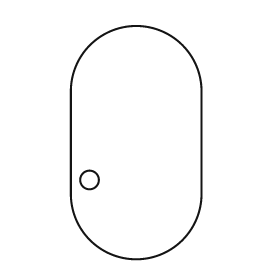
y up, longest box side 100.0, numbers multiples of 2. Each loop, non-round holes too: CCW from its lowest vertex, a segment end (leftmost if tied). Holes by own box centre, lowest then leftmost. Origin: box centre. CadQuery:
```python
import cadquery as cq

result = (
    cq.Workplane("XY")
    .moveTo(-28.0, -22.0)
    .threePointArc((0.0, -50.0), (28.0, -22.0))
    .lineTo(28.0, 22.0)
    .threePointArc((0.0, 50.0), (-28.0, 22.0))
    .close()
    .moveTo(-20.0, -16.0)
    .circle(4.0)
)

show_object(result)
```